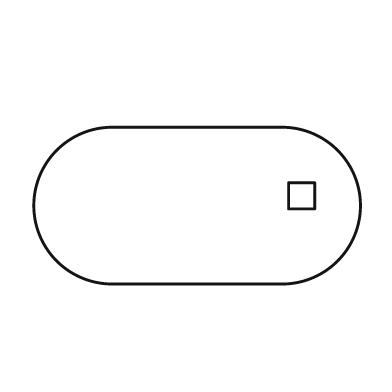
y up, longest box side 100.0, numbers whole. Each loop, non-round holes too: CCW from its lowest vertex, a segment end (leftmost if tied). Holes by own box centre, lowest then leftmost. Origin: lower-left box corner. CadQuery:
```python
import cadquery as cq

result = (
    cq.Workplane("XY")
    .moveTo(24.0, 0.0)
    .lineTo(76.0, 0.0)
    .threePointArc((100.0, 24.0), (76.0, 48.0))
    .lineTo(24.0, 48.0)
    .threePointArc((0.0, 24.0), (24.0, 0.0))
    .close()
    .moveTo(78.0, 23.0)
    .lineTo(86.0, 23.0)
    .lineTo(86.0, 31.0)
    .lineTo(78.0, 31.0)
    .close()
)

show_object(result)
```